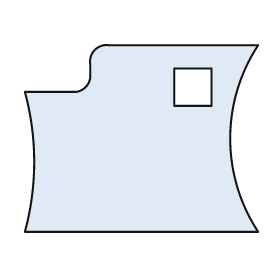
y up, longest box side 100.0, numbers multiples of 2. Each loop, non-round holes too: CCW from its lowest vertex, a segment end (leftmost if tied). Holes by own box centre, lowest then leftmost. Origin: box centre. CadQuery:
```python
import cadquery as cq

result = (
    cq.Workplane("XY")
    .moveTo(-50.0, -40.0)
    .lineTo(50.0, -40.0)
    .threePointArc((38.0, 0.0), (50.0, 40.0))
    .lineTo(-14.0, 40.0)
    .threePointArc((-20.0, 38.0), (-22.0, 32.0))
    .lineTo(-22.0, 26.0)
    .threePointArc((-24.0, 22.0), (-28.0, 20.0))
    .lineTo(-50.0, 20.0)
    .threePointArc((-46.0, -10.0), (-50.0, -40.0))
    .close()
    .moveTo(14.0, 14.0)
    .lineTo(30.0, 14.0)
    .lineTo(30.0, 30.0)
    .lineTo(14.0, 30.0)
    .close()
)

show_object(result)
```